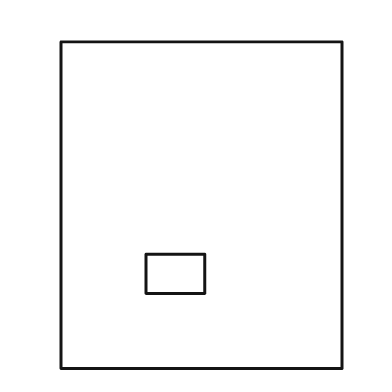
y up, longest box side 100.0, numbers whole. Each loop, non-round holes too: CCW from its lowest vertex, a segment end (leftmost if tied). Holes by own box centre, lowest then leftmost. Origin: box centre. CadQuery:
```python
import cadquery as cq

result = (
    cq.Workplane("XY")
    .moveTo(-43.0, -50.0)
    .lineTo(43.0, -50.0)
    .lineTo(43.0, 50.0)
    .lineTo(-43.0, 50.0)
    .close()
    .moveTo(-17.0, -27.0)
    .lineTo(1.0, -27.0)
    .lineTo(1.0, -15.0)
    .lineTo(-17.0, -15.0)
    .close()
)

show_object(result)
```